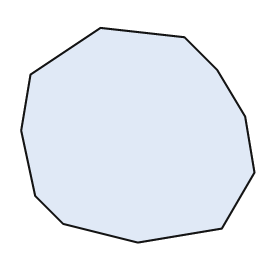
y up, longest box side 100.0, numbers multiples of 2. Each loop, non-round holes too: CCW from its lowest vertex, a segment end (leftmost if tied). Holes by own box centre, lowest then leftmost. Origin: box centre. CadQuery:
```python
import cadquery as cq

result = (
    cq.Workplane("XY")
    .moveTo(0.0, -46.0)
    .lineTo(36.0, -40.0)
    .lineTo(50.0, -16.0)
    .lineTo(46.0, 8.0)
    .lineTo(34.0, 28.0)
    .lineTo(20.0, 42.0)
    .lineTo(-16.0, 46.0)
    .lineTo(-46.0, 26.0)
    .lineTo(-50.0, 2.0)
    .lineTo(-44.0, -26.0)
    .lineTo(-32.0, -38.0)
    .close()
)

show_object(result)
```